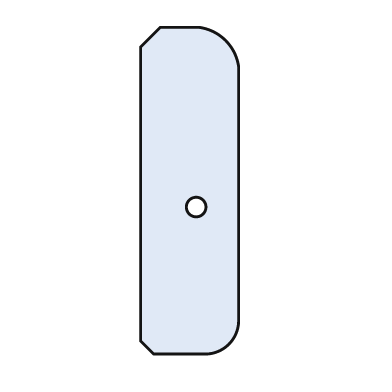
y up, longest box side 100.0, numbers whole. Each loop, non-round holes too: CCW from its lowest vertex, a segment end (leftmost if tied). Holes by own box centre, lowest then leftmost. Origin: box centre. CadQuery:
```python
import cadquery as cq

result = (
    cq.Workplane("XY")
    .moveTo(-11.0, -50.0)
    .lineTo(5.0, -50.0)
    .threePointArc((12.0, -47.0), (15.0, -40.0))
    .lineTo(15.0, 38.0)
    .threePointArc((11.0, 46.0), (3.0, 50.0))
    .lineTo(-9.0, 50.0)
    .lineTo(-15.0, 44.0)
    .lineTo(-15.0, -46.0)
    .close()
    .moveTo(2.0, -5.0)
    .circle(3.0)
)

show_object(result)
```